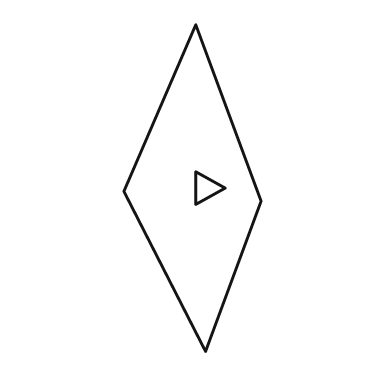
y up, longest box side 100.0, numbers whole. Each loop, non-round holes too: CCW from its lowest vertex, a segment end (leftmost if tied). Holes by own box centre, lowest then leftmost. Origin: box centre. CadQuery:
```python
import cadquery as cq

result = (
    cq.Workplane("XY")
    .moveTo(4.0, -50.0)
    .lineTo(21.0, -4.0)
    .lineTo(1.0, 50.0)
    .lineTo(-21.0, -1.0)
    .close()
    .moveTo(1.0, -5.0)
    .lineTo(10.0, 0.0)
    .lineTo(1.0, 5.0)
    .close()
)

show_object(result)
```